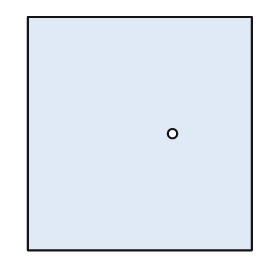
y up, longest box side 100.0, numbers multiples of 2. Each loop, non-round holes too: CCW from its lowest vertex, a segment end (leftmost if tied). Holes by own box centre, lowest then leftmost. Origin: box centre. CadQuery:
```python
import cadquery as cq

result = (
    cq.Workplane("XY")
    .moveTo(-48.0, -50.0)
    .lineTo(48.0, -50.0)
    .lineTo(48.0, 50.0)
    .lineTo(-48.0, 50.0)
    .close()
    .moveTo(14.0, 0.0)
    .circle(2.0)
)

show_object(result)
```